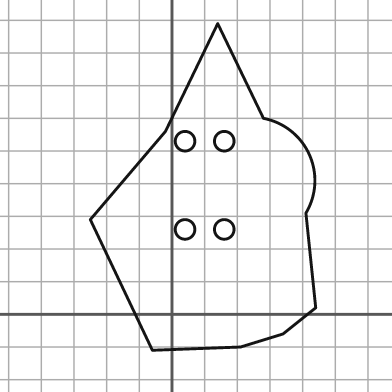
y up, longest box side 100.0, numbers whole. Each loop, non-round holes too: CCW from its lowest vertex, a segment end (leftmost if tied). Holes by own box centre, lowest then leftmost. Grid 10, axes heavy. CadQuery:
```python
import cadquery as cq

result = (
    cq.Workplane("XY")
    .moveTo(-6.0, -11.0)
    .lineTo(21.0, -10.0)
    .lineTo(34.0, -6.0)
    .lineTo(44.0, 2.0)
    .lineTo(41.0, 31.0)
    .threePointArc((42.0, 49.0), (28.0, 60.0))
    .lineTo(14.0, 89.0)
    .lineTo(-2.0, 56.0)
    .lineTo(-25.0, 29.0)
    .close()
    .moveTo(4.0, 26.0)
    .circle(3.0)
    .moveTo(16.0, 26.0)
    .circle(3.0)
    .moveTo(4.0, 53.0)
    .circle(3.0)
    .moveTo(16.0, 53.0)
    .circle(3.0)
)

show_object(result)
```